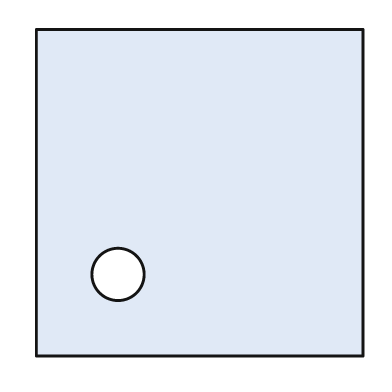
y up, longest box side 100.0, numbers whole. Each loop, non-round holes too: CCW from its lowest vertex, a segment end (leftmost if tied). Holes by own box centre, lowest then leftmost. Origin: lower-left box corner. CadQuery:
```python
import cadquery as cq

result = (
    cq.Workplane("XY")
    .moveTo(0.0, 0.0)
    .lineTo(100.0, 0.0)
    .lineTo(100.0, 100.0)
    .lineTo(0.0, 100.0)
    .close()
    .moveTo(25.0, 25.0)
    .circle(8.0)
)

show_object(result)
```